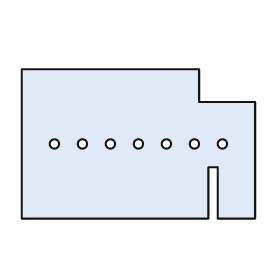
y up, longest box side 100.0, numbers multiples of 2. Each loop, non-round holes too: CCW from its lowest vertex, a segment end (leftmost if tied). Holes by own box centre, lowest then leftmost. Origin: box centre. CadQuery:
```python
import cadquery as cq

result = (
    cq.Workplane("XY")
    .moveTo(-50.0, -32.0)
    .lineTo(30.0, -32.0)
    .lineTo(30.0, -10.0)
    .lineTo(34.0, -10.0)
    .lineTo(34.0, -32.0)
    .lineTo(50.0, -32.0)
    .lineTo(50.0, 18.0)
    .lineTo(26.0, 18.0)
    .lineTo(26.0, 32.0)
    .lineTo(-50.0, 32.0)
    .close()
    .moveTo(-36.0, 0.0)
    .circle(2.0)
    .moveTo(-24.0, 0.0)
    .circle(2.0)
    .moveTo(-12.0, 0.0)
    .circle(2.0)
    .moveTo(0.0, 0.0)
    .circle(2.0)
    .moveTo(12.0, 0.0)
    .circle(2.0)
    .moveTo(24.0, 0.0)
    .circle(2.0)
    .moveTo(36.0, 0.0)
    .circle(2.0)
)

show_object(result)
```